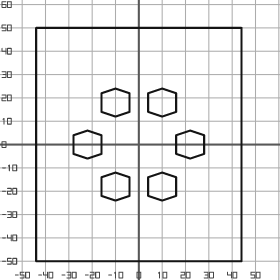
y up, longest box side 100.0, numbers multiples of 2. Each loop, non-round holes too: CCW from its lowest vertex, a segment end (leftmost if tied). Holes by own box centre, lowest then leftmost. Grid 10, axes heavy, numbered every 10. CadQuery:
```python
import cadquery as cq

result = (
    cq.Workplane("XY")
    .moveTo(-44.0, -50.0)
    .lineTo(44.0, -50.0)
    .lineTo(44.0, 50.0)
    .lineTo(-44.0, 50.0)
    .close()
    .moveTo(-10.0, -24.0)
    .lineTo(-4.0, -22.0)
    .lineTo(-4.0, -14.0)
    .lineTo(-10.0, -12.0)
    .lineTo(-16.0, -14.0)
    .lineTo(-16.0, -22.0)
    .close()
    .moveTo(10.0, -24.0)
    .lineTo(16.0, -22.0)
    .lineTo(16.0, -14.0)
    .lineTo(10.0, -12.0)
    .lineTo(4.0, -14.0)
    .lineTo(4.0, -22.0)
    .close()
    .moveTo(-22.0, -6.0)
    .lineTo(-16.0, -4.0)
    .lineTo(-16.0, 4.0)
    .lineTo(-22.0, 6.0)
    .lineTo(-28.0, 4.0)
    .lineTo(-28.0, -4.0)
    .close()
    .moveTo(22.0, -6.0)
    .lineTo(28.0, -4.0)
    .lineTo(28.0, 4.0)
    .lineTo(22.0, 6.0)
    .lineTo(16.0, 4.0)
    .lineTo(16.0, -4.0)
    .close()
    .moveTo(-10.0, 12.0)
    .lineTo(-4.0, 14.0)
    .lineTo(-4.0, 22.0)
    .lineTo(-10.0, 24.0)
    .lineTo(-16.0, 22.0)
    .lineTo(-16.0, 14.0)
    .close()
    .moveTo(10.0, 12.0)
    .lineTo(16.0, 14.0)
    .lineTo(16.0, 22.0)
    .lineTo(10.0, 24.0)
    .lineTo(4.0, 22.0)
    .lineTo(4.0, 14.0)
    .close()
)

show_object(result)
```